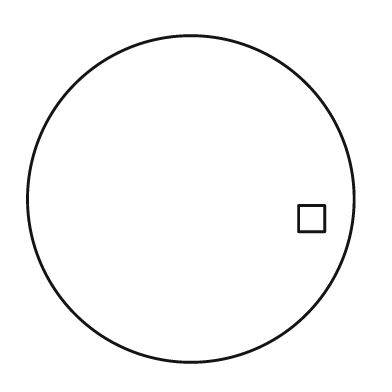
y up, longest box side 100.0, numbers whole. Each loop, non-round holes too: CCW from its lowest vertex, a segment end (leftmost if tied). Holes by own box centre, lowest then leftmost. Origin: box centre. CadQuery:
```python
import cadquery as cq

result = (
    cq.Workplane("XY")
    .moveTo(0.0, 0.0)
    .circle(50.0)
    .moveTo(33.0, -10.0)
    .lineTo(41.0, -10.0)
    .lineTo(41.0, -2.0)
    .lineTo(33.0, -2.0)
    .close()
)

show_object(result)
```